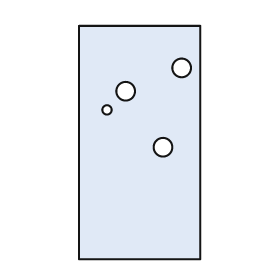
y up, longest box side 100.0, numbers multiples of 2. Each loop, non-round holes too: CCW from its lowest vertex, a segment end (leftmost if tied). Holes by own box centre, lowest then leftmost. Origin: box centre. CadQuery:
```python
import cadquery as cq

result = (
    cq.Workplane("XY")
    .moveTo(-26.0, -50.0)
    .lineTo(26.0, -50.0)
    .lineTo(26.0, 50.0)
    .lineTo(-26.0, 50.0)
    .close()
    .moveTo(10.0, -2.0)
    .circle(4.0)
    .moveTo(-14.0, 14.0)
    .circle(2.0)
    .moveTo(-6.0, 22.0)
    .circle(4.0)
    .moveTo(18.0, 32.0)
    .circle(4.0)
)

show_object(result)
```